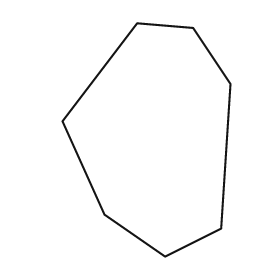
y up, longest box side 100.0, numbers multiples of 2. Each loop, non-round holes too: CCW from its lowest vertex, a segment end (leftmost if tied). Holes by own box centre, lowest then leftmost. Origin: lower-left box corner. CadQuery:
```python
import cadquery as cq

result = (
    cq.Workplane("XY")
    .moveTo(44.0, 0.0)
    .lineTo(68.0, 12.0)
    .lineTo(72.0, 74.0)
    .lineTo(56.0, 98.0)
    .lineTo(32.0, 100.0)
    .lineTo(0.0, 58.0)
    .lineTo(18.0, 18.0)
    .close()
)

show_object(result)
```